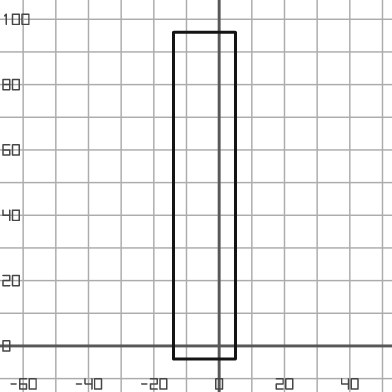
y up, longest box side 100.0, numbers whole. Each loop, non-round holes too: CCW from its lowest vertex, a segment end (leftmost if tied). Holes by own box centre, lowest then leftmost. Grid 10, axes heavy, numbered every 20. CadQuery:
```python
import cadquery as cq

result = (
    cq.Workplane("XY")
    .moveTo(-14.0, -4.0)
    .lineTo(5.0, -4.0)
    .lineTo(5.0, 96.0)
    .lineTo(-14.0, 96.0)
    .close()
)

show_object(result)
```